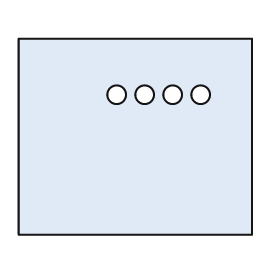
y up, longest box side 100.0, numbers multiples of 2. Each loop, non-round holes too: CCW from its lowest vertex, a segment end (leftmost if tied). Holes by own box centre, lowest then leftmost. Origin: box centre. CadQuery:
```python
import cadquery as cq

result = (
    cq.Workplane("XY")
    .moveTo(-50.0, -42.0)
    .lineTo(50.0, -42.0)
    .lineTo(50.0, 42.0)
    .lineTo(-50.0, 42.0)
    .close()
    .moveTo(-8.0, 18.0)
    .circle(4.0)
    .moveTo(4.0, 18.0)
    .circle(4.0)
    .moveTo(16.0, 18.0)
    .circle(4.0)
    .moveTo(28.0, 18.0)
    .circle(4.0)
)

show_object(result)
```